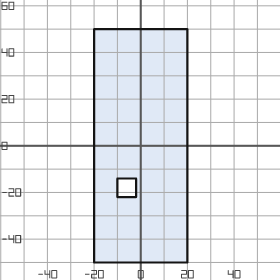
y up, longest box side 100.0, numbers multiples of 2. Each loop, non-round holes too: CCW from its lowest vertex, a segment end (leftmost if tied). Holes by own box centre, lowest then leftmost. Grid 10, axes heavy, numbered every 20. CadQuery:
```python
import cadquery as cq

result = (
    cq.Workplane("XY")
    .moveTo(-20.0, -50.0)
    .lineTo(20.0, -50.0)
    .lineTo(20.0, 50.0)
    .lineTo(-20.0, 50.0)
    .close()
    .moveTo(-10.0, -22.0)
    .lineTo(-2.0, -22.0)
    .lineTo(-2.0, -14.0)
    .lineTo(-10.0, -14.0)
    .close()
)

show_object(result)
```